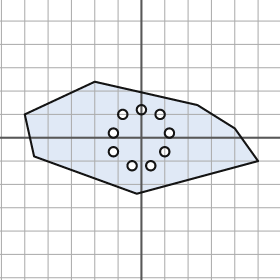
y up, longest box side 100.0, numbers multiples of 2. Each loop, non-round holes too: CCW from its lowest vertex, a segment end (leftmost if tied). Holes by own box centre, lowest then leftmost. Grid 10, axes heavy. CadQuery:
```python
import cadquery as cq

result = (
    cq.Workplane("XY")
    .moveTo(-2.0, -24.0)
    .lineTo(50.0, -10.0)
    .lineTo(40.0, 4.0)
    .lineTo(24.0, 14.0)
    .lineTo(-20.0, 24.0)
    .lineTo(-50.0, 10.0)
    .lineTo(-46.0, -8.0)
    .close()
    .moveTo(-4.0, -12.0)
    .circle(2.0)
    .moveTo(4.0, -12.0)
    .circle(2.0)
    .moveTo(-12.0, -6.0)
    .circle(2.0)
    .moveTo(10.0, -6.0)
    .circle(2.0)
    .moveTo(-12.0, 2.0)
    .circle(2.0)
    .moveTo(12.0, 2.0)
    .circle(2.0)
    .moveTo(-8.0, 10.0)
    .circle(2.0)
    .moveTo(8.0, 10.0)
    .circle(2.0)
    .moveTo(0.0, 12.0)
    .circle(2.0)
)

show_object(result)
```